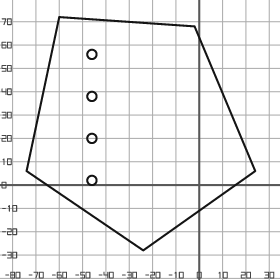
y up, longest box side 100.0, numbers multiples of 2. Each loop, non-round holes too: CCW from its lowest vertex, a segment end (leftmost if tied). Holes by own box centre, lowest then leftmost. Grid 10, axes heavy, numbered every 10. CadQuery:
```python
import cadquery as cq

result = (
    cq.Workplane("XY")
    .moveTo(-24.0, -28.0)
    .lineTo(24.0, 6.0)
    .lineTo(-2.0, 68.0)
    .lineTo(-60.0, 72.0)
    .lineTo(-74.0, 6.0)
    .close()
    .moveTo(-46.0, 2.0)
    .circle(2.0)
    .moveTo(-46.0, 20.0)
    .circle(2.0)
    .moveTo(-46.0, 38.0)
    .circle(2.0)
    .moveTo(-46.0, 56.0)
    .circle(2.0)
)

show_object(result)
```